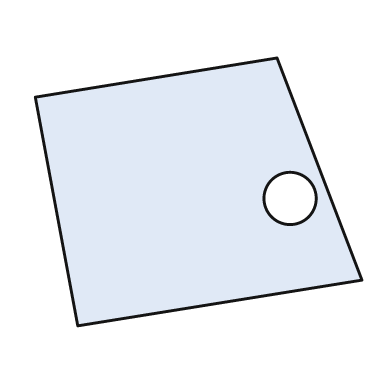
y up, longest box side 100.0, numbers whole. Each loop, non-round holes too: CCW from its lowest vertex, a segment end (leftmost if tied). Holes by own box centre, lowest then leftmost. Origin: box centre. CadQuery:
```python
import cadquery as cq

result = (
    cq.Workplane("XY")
    .moveTo(-37.0, -41.0)
    .lineTo(50.0, -27.0)
    .lineTo(24.0, 41.0)
    .lineTo(-50.0, 29.0)
    .close()
    .moveTo(28.0, -2.0)
    .circle(8.0)
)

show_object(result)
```